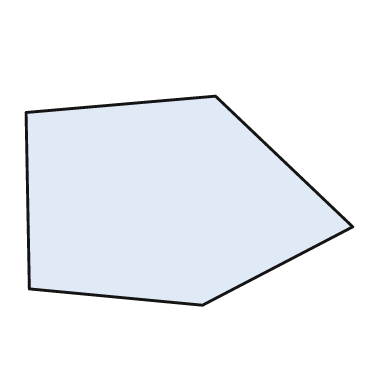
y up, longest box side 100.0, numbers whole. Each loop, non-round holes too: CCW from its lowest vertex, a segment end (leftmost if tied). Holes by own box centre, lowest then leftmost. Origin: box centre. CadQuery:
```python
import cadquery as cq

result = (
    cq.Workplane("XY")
    .moveTo(4.0, -32.0)
    .lineTo(50.0, -8.0)
    .lineTo(8.0, 32.0)
    .lineTo(-50.0, 27.0)
    .lineTo(-49.0, -27.0)
    .close()
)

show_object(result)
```